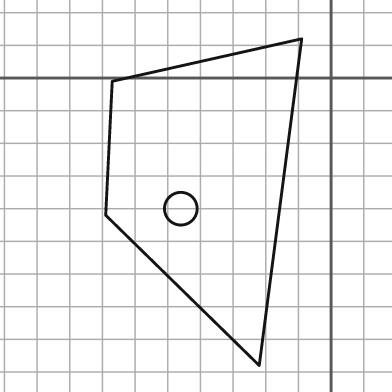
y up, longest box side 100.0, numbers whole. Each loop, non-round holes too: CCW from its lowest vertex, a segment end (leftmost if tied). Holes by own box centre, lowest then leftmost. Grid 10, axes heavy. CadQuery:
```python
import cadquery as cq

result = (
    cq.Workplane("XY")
    .moveTo(-22.0, -88.0)
    .lineTo(-9.0, 12.0)
    .lineTo(-67.0, -1.0)
    .lineTo(-69.0, -42.0)
    .close()
    .moveTo(-46.0, -40.0)
    .circle(5.0)
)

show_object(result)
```